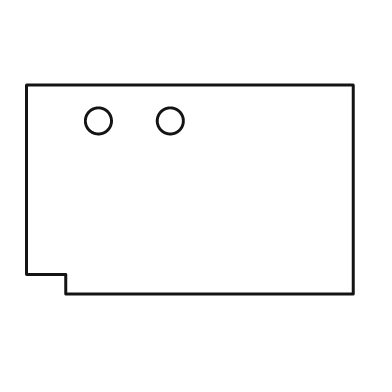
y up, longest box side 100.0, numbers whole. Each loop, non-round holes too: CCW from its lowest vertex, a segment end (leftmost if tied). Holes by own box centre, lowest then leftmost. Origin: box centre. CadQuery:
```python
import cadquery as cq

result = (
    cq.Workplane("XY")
    .moveTo(-38.0, -32.0)
    .lineTo(50.0, -32.0)
    .lineTo(50.0, 32.0)
    .lineTo(-50.0, 32.0)
    .lineTo(-50.0, -26.0)
    .lineTo(-38.0, -26.0)
    .close()
    .moveTo(-28.0, 21.0)
    .circle(4.0)
    .moveTo(-6.0, 21.0)
    .circle(4.0)
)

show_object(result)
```